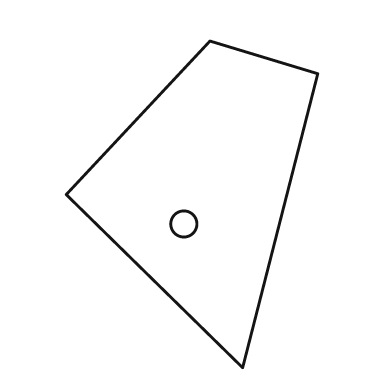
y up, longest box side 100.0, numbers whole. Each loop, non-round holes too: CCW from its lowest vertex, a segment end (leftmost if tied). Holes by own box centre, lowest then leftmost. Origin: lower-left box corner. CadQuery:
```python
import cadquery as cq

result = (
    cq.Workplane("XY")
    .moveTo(54.0, 0.0)
    .lineTo(77.0, 90.0)
    .lineTo(44.0, 100.0)
    .lineTo(0.0, 53.0)
    .close()
    .moveTo(36.0, 44.0)
    .circle(4.0)
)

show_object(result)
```